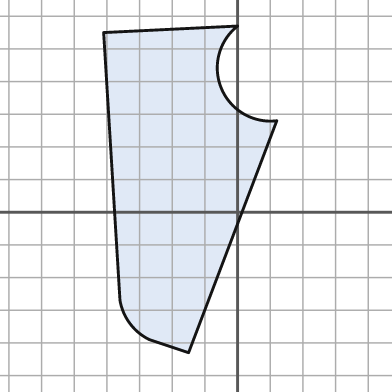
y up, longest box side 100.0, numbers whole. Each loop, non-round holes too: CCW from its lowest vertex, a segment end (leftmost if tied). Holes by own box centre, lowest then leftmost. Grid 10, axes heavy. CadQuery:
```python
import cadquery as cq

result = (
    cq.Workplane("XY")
    .moveTo(-15.0, -43.0)
    .lineTo(12.0, 28.0)
    .threePointArc((-5.0, 38.0), (0.0, 57.0))
    .lineTo(-41.0, 55.0)
    .lineTo(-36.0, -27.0)
    .threePointArc((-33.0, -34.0), (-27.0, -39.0))
    .close()
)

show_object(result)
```